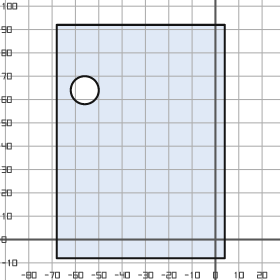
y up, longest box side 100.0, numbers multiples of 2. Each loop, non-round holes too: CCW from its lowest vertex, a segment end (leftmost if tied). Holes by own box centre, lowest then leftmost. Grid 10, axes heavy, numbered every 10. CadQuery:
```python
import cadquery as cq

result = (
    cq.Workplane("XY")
    .moveTo(-68.0, -8.0)
    .lineTo(4.0, -8.0)
    .lineTo(4.0, 92.0)
    .lineTo(-68.0, 92.0)
    .close()
    .moveTo(-56.0, 64.0)
    .circle(6.0)
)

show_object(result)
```